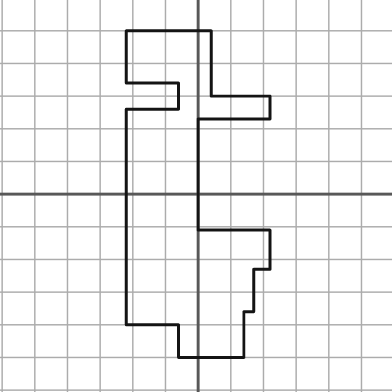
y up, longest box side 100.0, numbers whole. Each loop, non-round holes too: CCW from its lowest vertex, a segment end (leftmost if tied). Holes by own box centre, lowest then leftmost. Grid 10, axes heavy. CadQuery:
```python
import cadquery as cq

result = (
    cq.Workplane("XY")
    .moveTo(-6.0, -50.0)
    .lineTo(14.0, -50.0)
    .lineTo(14.0, -36.0)
    .lineTo(17.0, -36.0)
    .lineTo(17.0, -23.0)
    .lineTo(22.0, -23.0)
    .lineTo(22.0, -11.0)
    .lineTo(0.0, -11.0)
    .lineTo(0.0, 23.0)
    .lineTo(22.0, 23.0)
    .lineTo(22.0, 30.0)
    .lineTo(4.0, 30.0)
    .lineTo(4.0, 50.0)
    .lineTo(-22.0, 50.0)
    .lineTo(-22.0, 34.0)
    .lineTo(-6.0, 34.0)
    .lineTo(-6.0, 26.0)
    .lineTo(-22.0, 26.0)
    .lineTo(-22.0, -40.0)
    .lineTo(-6.0, -40.0)
    .close()
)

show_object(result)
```